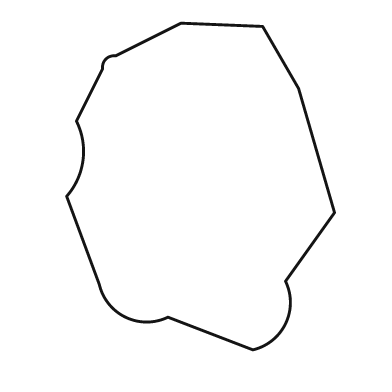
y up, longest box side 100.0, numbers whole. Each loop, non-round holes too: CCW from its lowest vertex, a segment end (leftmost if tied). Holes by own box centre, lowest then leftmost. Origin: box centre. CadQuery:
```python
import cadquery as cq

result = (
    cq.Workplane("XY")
    .moveTo(16.0, -50.0)
    .threePointArc((26.0, -42.0), (26.0, -29.0))
    .lineTo(41.0, -8.0)
    .lineTo(30.0, 30.0)
    .lineTo(19.0, 49.0)
    .lineTo(-6.0, 50.0)
    .lineTo(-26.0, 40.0)
    .threePointArc((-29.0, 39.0), (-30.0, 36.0))
    .lineTo(-38.0, 20.0)
    .threePointArc((-36.0, 8.0), (-41.0, -3.0))
    .lineTo(-31.0, -30.0)
    .threePointArc((-23.0, -40.0), (-10.0, -40.0))
    .close()
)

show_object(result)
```